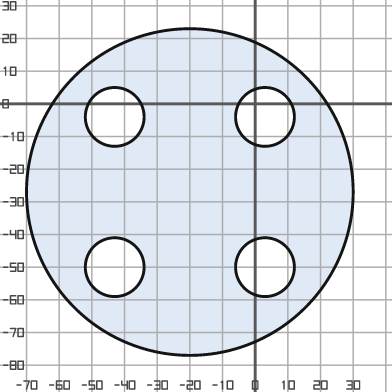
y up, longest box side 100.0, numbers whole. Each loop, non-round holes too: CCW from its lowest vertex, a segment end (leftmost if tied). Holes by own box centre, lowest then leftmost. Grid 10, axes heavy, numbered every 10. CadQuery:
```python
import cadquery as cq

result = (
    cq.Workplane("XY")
    .moveTo(-20.0, -27.0)
    .circle(50.0)
    .moveTo(-43.0, -50.0)
    .circle(9.0)
    .moveTo(3.0, -50.0)
    .circle(9.0)
    .moveTo(-43.0, -4.0)
    .circle(9.0)
    .moveTo(3.0, -4.0)
    .circle(9.0)
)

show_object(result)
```